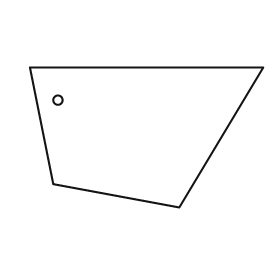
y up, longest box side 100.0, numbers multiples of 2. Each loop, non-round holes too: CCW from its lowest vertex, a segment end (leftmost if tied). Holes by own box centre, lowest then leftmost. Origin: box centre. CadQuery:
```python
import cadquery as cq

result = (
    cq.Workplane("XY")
    .moveTo(14.0, -30.0)
    .lineTo(50.0, 30.0)
    .lineTo(-50.0, 30.0)
    .lineTo(-40.0, -20.0)
    .close()
    .moveTo(-38.0, 16.0)
    .circle(2.0)
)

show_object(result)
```